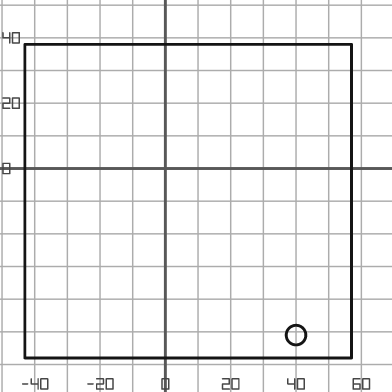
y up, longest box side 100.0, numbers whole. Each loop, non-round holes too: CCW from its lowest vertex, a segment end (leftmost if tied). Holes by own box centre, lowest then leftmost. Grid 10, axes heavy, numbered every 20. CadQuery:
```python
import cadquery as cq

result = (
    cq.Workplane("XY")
    .moveTo(-43.0, -58.0)
    .lineTo(57.0, -58.0)
    .lineTo(57.0, 38.0)
    .lineTo(-43.0, 38.0)
    .close()
    .moveTo(40.0, -51.0)
    .circle(3.0)
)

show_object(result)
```